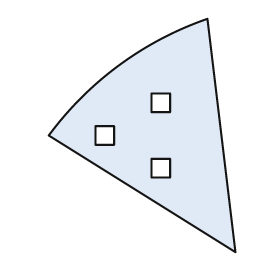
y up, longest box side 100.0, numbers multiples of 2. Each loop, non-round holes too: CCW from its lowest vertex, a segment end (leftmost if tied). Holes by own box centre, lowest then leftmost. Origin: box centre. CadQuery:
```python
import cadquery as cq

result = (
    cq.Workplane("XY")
    .moveTo(40.0, -50.0)
    .lineTo(28.0, 50.0)
    .threePointArc((-10.0, 30.0), (-40.0, 0.0))
    .close()
    .moveTo(4.0, -18.0)
    .lineTo(12.0, -18.0)
    .lineTo(12.0, -10.0)
    .lineTo(4.0, -10.0)
    .close()
    .moveTo(-20.0, -4.0)
    .lineTo(-12.0, -4.0)
    .lineTo(-12.0, 4.0)
    .lineTo(-20.0, 4.0)
    .close()
    .moveTo(4.0, 10.0)
    .lineTo(12.0, 10.0)
    .lineTo(12.0, 18.0)
    .lineTo(4.0, 18.0)
    .close()
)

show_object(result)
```